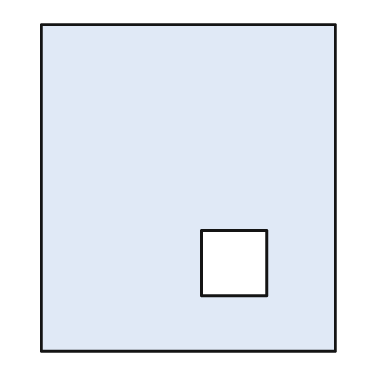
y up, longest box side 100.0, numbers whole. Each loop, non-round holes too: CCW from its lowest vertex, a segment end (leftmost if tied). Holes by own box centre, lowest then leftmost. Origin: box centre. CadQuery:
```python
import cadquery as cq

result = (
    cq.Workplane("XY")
    .moveTo(-45.0, -50.0)
    .lineTo(45.0, -50.0)
    .lineTo(45.0, 50.0)
    .lineTo(-45.0, 50.0)
    .close()
    .moveTo(4.0, -33.0)
    .lineTo(24.0, -33.0)
    .lineTo(24.0, -13.0)
    .lineTo(4.0, -13.0)
    .close()
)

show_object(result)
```